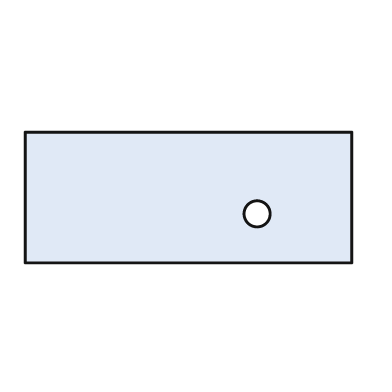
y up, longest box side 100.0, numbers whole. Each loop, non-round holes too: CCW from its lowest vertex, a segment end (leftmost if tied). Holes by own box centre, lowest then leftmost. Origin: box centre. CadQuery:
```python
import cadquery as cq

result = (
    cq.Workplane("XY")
    .moveTo(-50.0, -20.0)
    .lineTo(50.0, -20.0)
    .lineTo(50.0, 20.0)
    .lineTo(-50.0, 20.0)
    .close()
    .moveTo(21.0, -5.0)
    .circle(4.0)
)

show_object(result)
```